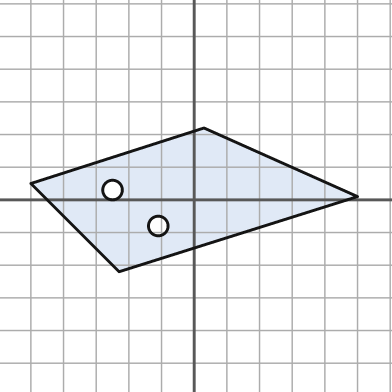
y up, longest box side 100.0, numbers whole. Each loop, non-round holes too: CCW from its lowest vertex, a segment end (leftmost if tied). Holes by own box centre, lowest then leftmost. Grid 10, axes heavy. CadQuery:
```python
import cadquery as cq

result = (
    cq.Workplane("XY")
    .moveTo(-23.0, -22.0)
    .lineTo(50.0, 1.0)
    .lineTo(3.0, 22.0)
    .lineTo(-50.0, 5.0)
    .close()
    .moveTo(-11.0, -8.0)
    .circle(3.0)
    .moveTo(-25.0, 3.0)
    .circle(3.0)
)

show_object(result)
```